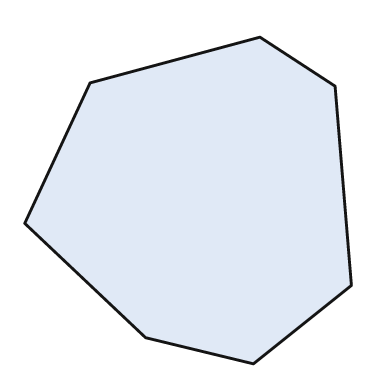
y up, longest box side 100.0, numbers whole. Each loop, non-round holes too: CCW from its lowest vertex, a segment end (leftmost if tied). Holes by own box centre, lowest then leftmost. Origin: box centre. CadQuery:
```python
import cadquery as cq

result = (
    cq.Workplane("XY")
    .moveTo(20.0, -50.0)
    .lineTo(50.0, -26.0)
    .lineTo(45.0, 35.0)
    .lineTo(22.0, 50.0)
    .lineTo(-30.0, 36.0)
    .lineTo(-50.0, -7.0)
    .lineTo(-13.0, -42.0)
    .close()
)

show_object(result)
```